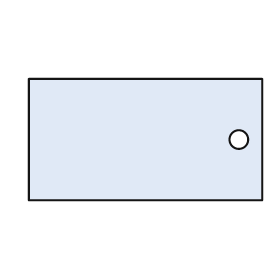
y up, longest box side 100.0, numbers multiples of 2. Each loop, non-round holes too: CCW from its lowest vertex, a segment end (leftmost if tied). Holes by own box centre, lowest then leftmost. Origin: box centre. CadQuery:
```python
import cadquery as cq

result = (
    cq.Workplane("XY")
    .moveTo(-50.0, -26.0)
    .lineTo(50.0, -26.0)
    .lineTo(50.0, 26.0)
    .lineTo(-50.0, 26.0)
    .close()
    .moveTo(40.0, 0.0)
    .circle(4.0)
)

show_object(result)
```